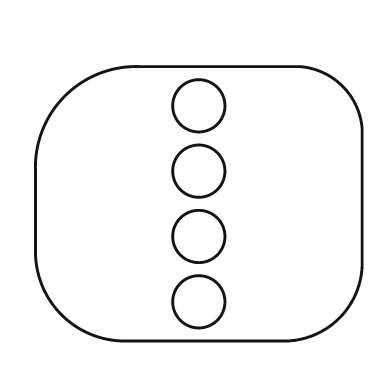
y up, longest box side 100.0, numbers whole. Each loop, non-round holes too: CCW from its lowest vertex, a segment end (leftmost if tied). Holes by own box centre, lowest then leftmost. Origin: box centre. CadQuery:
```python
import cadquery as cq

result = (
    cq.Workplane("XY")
    .moveTo(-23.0, -42.0)
    .lineTo(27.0, -42.0)
    .threePointArc((43.0, -35.0), (50.0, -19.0))
    .lineTo(50.0, 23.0)
    .threePointArc((44.0, 36.0), (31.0, 42.0))
    .lineTo(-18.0, 42.0)
    .threePointArc((-41.0, 33.0), (-50.0, 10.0))
    .lineTo(-50.0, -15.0)
    .threePointArc((-42.0, -34.0), (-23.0, -42.0))
    .close()
    .moveTo(0.0, -30.0)
    .circle(8.0)
    .moveTo(0.0, -10.0)
    .circle(8.0)
    .moveTo(0.0, 10.0)
    .circle(8.0)
    .moveTo(0.0, 30.0)
    .circle(8.0)
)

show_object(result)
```